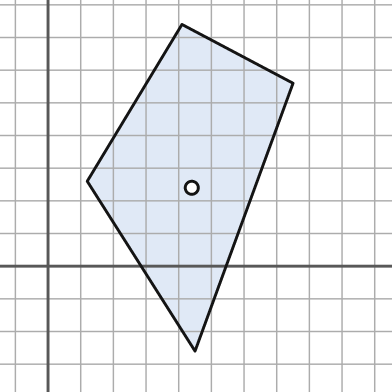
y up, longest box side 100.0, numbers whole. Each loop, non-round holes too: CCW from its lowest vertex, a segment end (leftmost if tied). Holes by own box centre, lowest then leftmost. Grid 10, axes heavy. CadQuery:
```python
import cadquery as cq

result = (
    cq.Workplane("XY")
    .moveTo(45.0, -26.0)
    .lineTo(75.0, 56.0)
    .lineTo(41.0, 74.0)
    .lineTo(12.0, 26.0)
    .close()
    .moveTo(44.0, 24.0)
    .circle(2.0)
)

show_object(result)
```